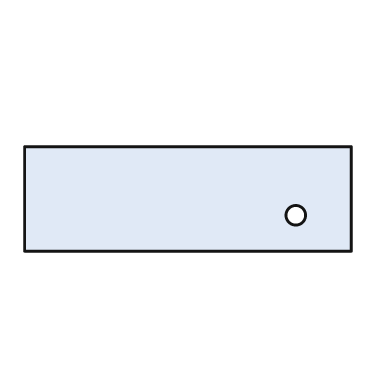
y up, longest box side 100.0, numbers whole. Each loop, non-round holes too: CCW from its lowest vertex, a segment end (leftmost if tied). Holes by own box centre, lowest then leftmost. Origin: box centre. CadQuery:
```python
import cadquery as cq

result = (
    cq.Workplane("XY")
    .moveTo(-50.0, -16.0)
    .lineTo(50.0, -16.0)
    .lineTo(50.0, 16.0)
    .lineTo(-50.0, 16.0)
    .close()
    .moveTo(33.0, -5.0)
    .circle(3.0)
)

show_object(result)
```